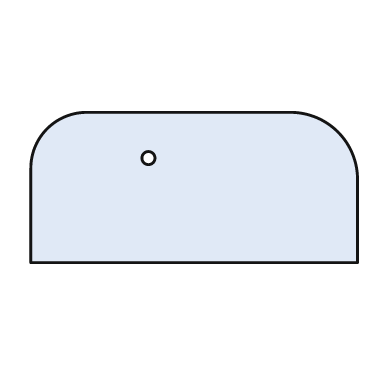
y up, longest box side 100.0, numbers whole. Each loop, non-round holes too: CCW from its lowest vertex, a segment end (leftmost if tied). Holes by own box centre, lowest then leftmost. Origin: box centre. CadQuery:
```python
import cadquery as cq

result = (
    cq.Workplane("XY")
    .moveTo(-50.0, -23.0)
    .lineTo(50.0, -23.0)
    .lineTo(50.0, 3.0)
    .threePointArc((44.0, 17.0), (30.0, 23.0))
    .lineTo(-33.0, 23.0)
    .threePointArc((-45.0, 18.0), (-50.0, 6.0))
    .close()
    .moveTo(-14.0, 9.0)
    .circle(2.0)
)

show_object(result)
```